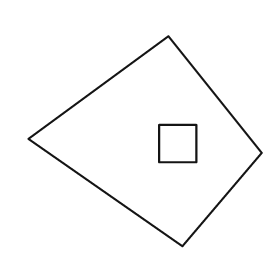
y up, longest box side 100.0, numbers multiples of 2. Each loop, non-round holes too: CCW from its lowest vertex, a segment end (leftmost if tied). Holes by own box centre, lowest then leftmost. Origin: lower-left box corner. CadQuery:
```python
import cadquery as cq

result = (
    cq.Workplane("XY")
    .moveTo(66.0, 0.0)
    .lineTo(100.0, 40.0)
    .lineTo(60.0, 90.0)
    .lineTo(0.0, 46.0)
    .close()
    .moveTo(56.0, 36.0)
    .lineTo(72.0, 36.0)
    .lineTo(72.0, 52.0)
    .lineTo(56.0, 52.0)
    .close()
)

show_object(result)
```